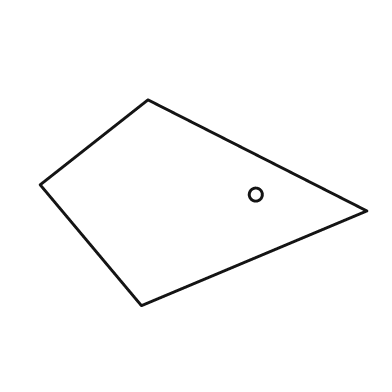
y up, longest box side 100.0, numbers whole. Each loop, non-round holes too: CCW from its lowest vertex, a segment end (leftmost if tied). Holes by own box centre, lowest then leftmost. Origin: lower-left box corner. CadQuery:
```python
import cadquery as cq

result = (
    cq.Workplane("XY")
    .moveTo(31.0, 0.0)
    .lineTo(100.0, 29.0)
    .lineTo(33.0, 63.0)
    .lineTo(0.0, 37.0)
    .close()
    .moveTo(66.0, 34.0)
    .circle(2.0)
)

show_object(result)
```